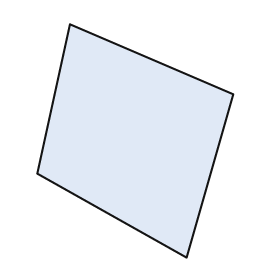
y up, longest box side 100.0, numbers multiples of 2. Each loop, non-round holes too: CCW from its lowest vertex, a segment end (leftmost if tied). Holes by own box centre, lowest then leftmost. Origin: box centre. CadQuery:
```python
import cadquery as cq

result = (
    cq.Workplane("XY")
    .moveTo(22.0, -50.0)
    .lineTo(42.0, 20.0)
    .lineTo(-28.0, 50.0)
    .lineTo(-42.0, -14.0)
    .close()
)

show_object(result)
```